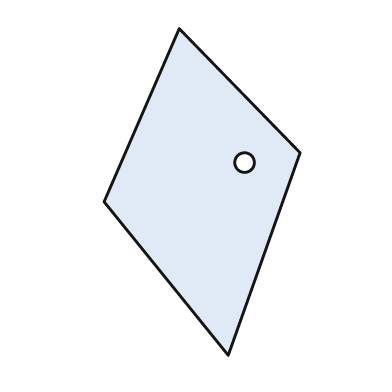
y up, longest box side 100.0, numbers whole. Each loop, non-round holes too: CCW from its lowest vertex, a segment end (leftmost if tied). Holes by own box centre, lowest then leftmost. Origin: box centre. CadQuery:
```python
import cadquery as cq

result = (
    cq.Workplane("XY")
    .moveTo(8.0, -50.0)
    .lineTo(30.0, 12.0)
    .lineTo(-7.0, 50.0)
    .lineTo(-30.0, -3.0)
    .close()
    .moveTo(13.0, 9.0)
    .circle(3.0)
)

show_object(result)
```